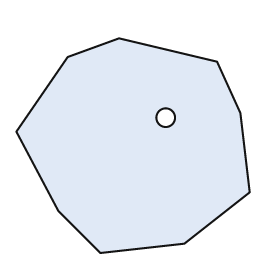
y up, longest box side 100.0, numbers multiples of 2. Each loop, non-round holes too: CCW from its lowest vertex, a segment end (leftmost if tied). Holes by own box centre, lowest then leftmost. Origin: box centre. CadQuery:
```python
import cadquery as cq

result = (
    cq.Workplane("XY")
    .moveTo(-14.0, -46.0)
    .lineTo(22.0, -42.0)
    .lineTo(50.0, -20.0)
    .lineTo(46.0, 14.0)
    .lineTo(36.0, 36.0)
    .lineTo(-6.0, 46.0)
    .lineTo(-28.0, 38.0)
    .lineTo(-50.0, 6.0)
    .lineTo(-32.0, -28.0)
    .close()
    .moveTo(14.0, 12.0)
    .circle(4.0)
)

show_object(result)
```